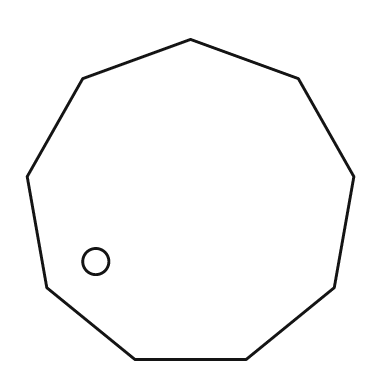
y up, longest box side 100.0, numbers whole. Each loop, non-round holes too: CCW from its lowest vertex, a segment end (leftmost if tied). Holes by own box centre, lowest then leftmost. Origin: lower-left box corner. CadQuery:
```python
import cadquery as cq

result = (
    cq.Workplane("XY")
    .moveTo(33.0, 0.0)
    .lineTo(67.0, 0.0)
    .lineTo(94.0, 22.0)
    .lineTo(100.0, 56.0)
    .lineTo(83.0, 86.0)
    .lineTo(50.0, 98.0)
    .lineTo(17.0, 86.0)
    .lineTo(0.0, 56.0)
    .lineTo(6.0, 22.0)
    .close()
    .moveTo(21.0, 30.0)
    .circle(4.0)
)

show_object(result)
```